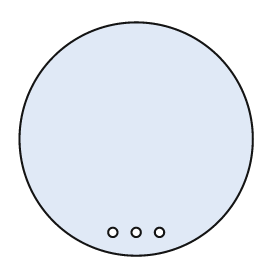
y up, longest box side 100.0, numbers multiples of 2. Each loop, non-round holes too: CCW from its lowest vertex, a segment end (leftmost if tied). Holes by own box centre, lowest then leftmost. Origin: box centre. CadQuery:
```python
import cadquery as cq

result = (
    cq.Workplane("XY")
    .moveTo(0.0, 0.0)
    .circle(50.0)
    .moveTo(-10.0, -40.0)
    .circle(2.0)
    .moveTo(0.0, -40.0)
    .circle(2.0)
    .moveTo(10.0, -40.0)
    .circle(2.0)
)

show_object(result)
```